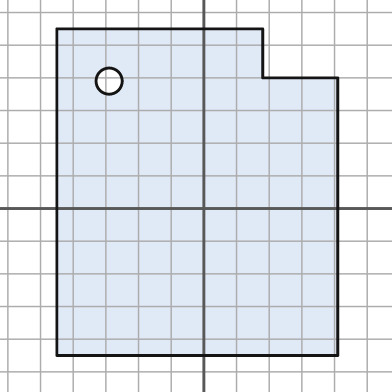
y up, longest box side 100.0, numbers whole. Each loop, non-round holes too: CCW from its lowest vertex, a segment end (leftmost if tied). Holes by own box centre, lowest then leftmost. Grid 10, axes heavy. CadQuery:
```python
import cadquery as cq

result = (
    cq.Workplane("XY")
    .moveTo(-45.0, -45.0)
    .lineTo(41.0, -45.0)
    .lineTo(41.0, 40.0)
    .lineTo(18.0, 40.0)
    .lineTo(18.0, 55.0)
    .lineTo(-45.0, 55.0)
    .close()
    .moveTo(-29.0, 39.0)
    .circle(4.0)
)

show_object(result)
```